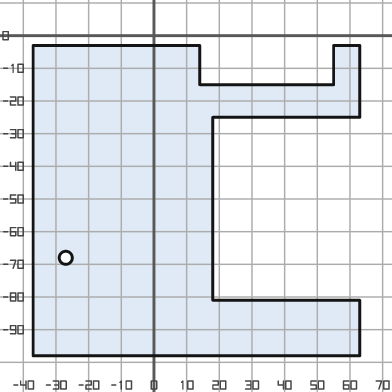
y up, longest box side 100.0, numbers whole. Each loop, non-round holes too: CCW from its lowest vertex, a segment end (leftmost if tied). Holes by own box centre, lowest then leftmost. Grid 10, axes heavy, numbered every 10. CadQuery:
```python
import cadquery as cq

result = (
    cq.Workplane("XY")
    .moveTo(-37.0, -98.0)
    .lineTo(63.0, -98.0)
    .lineTo(63.0, -81.0)
    .lineTo(18.0, -81.0)
    .lineTo(18.0, -25.0)
    .lineTo(63.0, -25.0)
    .lineTo(63.0, -3.0)
    .lineTo(55.0, -3.0)
    .lineTo(55.0, -15.0)
    .lineTo(14.0, -15.0)
    .lineTo(14.0, -3.0)
    .lineTo(-37.0, -3.0)
    .close()
    .moveTo(-27.0, -68.0)
    .circle(2.0)
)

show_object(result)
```